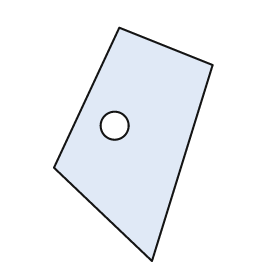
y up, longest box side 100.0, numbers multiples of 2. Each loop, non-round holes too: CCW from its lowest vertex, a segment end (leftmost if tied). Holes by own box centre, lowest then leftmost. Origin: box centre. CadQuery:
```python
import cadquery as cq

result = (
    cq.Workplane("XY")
    .moveTo(8.0, -50.0)
    .lineTo(34.0, 34.0)
    .lineTo(-6.0, 50.0)
    .lineTo(-34.0, -10.0)
    .close()
    .moveTo(-8.0, 8.0)
    .circle(6.0)
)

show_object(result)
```